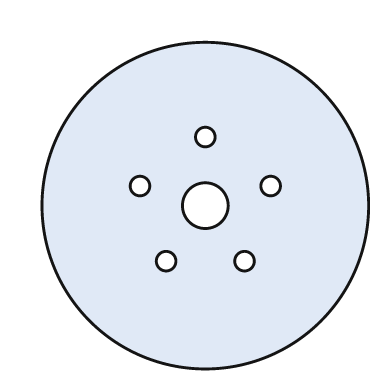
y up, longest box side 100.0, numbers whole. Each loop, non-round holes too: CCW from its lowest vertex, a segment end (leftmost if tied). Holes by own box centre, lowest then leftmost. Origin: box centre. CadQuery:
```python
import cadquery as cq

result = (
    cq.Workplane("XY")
    .moveTo(0.0, 0.0)
    .circle(50.0)
    .moveTo(-12.0, -17.0)
    .circle(3.0)
    .moveTo(12.0, -17.0)
    .circle(3.0)
    .moveTo(0.0, 0.0)
    .circle(7.0)
    .moveTo(-20.0, 6.0)
    .circle(3.0)
    .moveTo(20.0, 6.0)
    .circle(3.0)
    .moveTo(0.0, 21.0)
    .circle(3.0)
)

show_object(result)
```